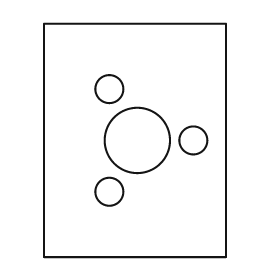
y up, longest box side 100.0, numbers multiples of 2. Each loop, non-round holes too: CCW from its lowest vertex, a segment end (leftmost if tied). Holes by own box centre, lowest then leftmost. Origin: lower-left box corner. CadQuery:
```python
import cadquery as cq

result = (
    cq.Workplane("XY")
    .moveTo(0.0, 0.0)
    .lineTo(78.0, 0.0)
    .lineTo(78.0, 100.0)
    .lineTo(0.0, 100.0)
    .close()
    .moveTo(28.0, 28.0)
    .circle(6.0)
    .moveTo(40.0, 50.0)
    .circle(14.0)
    .moveTo(64.0, 50.0)
    .circle(6.0)
    .moveTo(28.0, 72.0)
    .circle(6.0)
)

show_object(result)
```